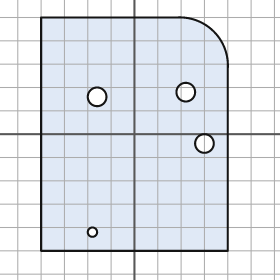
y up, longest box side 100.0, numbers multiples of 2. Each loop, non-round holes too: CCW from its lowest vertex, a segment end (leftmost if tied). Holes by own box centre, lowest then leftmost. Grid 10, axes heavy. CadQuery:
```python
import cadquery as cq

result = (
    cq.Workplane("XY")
    .moveTo(-40.0, -50.0)
    .lineTo(40.0, -50.0)
    .lineTo(40.0, 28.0)
    .threePointArc((34.0, 44.0), (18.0, 50.0))
    .lineTo(-40.0, 50.0)
    .close()
    .moveTo(-18.0, -42.0)
    .circle(2.0)
    .moveTo(30.0, -4.0)
    .circle(4.0)
    .moveTo(-16.0, 16.0)
    .circle(4.0)
    .moveTo(22.0, 18.0)
    .circle(4.0)
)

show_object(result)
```